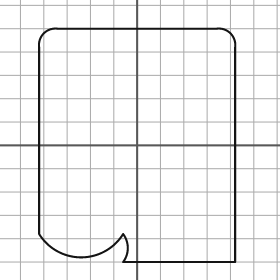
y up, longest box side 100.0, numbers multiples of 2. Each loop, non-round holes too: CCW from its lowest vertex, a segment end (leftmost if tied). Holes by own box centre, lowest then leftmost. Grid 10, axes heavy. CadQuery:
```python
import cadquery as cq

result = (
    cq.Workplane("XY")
    .moveTo(-6.0, -50.0)
    .lineTo(42.0, -50.0)
    .lineTo(42.0, 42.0)
    .threePointArc((40.0, 48.0), (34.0, 50.0))
    .lineTo(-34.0, 50.0)
    .threePointArc((-40.0, 48.0), (-42.0, 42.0))
    .lineTo(-42.0, -38.0)
    .threePointArc((-24.0, -48.0), (-6.0, -38.0))
    .threePointArc((-4.0, -44.0), (-6.0, -50.0))
    .close()
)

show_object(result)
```